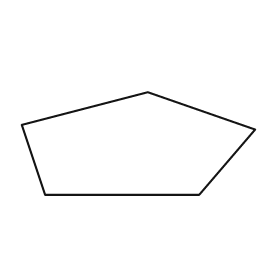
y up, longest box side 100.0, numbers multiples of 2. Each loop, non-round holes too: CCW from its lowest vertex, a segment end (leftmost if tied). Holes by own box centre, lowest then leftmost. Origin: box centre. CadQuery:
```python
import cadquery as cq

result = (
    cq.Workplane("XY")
    .moveTo(-40.0, -22.0)
    .lineTo(26.0, -22.0)
    .lineTo(50.0, 6.0)
    .lineTo(4.0, 22.0)
    .lineTo(-50.0, 8.0)
    .close()
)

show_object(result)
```